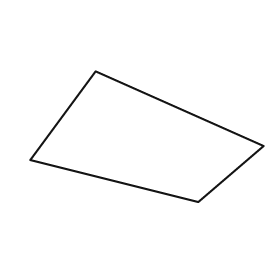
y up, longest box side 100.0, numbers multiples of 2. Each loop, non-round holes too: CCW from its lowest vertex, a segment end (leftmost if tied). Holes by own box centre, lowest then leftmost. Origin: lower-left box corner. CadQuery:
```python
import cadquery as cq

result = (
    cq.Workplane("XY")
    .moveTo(72.0, 0.0)
    .lineTo(100.0, 24.0)
    .lineTo(28.0, 56.0)
    .lineTo(0.0, 18.0)
    .close()
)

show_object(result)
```